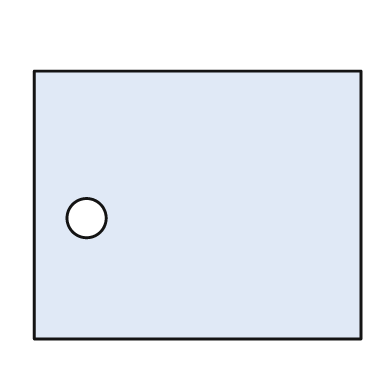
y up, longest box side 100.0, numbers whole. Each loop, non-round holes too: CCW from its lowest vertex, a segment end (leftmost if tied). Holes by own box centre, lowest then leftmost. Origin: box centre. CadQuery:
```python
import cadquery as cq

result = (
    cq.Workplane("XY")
    .moveTo(-50.0, -41.0)
    .lineTo(50.0, -41.0)
    .lineTo(50.0, 41.0)
    .lineTo(-50.0, 41.0)
    .close()
    .moveTo(-34.0, -4.0)
    .circle(6.0)
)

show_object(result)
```